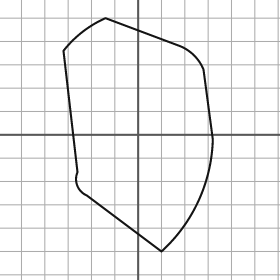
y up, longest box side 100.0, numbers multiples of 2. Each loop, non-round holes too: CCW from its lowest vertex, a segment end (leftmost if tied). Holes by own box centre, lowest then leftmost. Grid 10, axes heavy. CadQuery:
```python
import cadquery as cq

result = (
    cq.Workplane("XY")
    .moveTo(10.0, -50.0)
    .threePointArc((26.0, -28.0), (32.0, -2.0))
    .lineTo(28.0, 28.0)
    .threePointArc((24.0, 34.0), (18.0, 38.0))
    .lineTo(-14.0, 50.0)
    .threePointArc((-24.0, 44.0), (-32.0, 36.0))
    .lineTo(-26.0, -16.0)
    .threePointArc((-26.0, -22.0), (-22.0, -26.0))
    .close()
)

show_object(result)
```